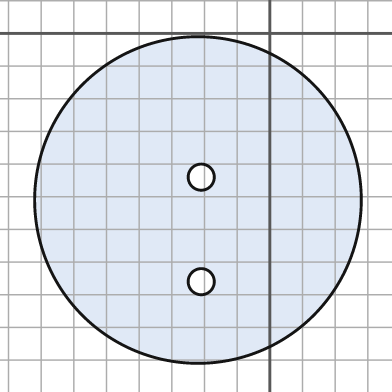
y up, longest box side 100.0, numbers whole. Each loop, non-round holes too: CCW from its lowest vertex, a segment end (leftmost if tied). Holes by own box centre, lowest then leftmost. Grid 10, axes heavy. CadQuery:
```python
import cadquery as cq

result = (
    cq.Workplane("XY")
    .moveTo(-22.0, -51.0)
    .circle(50.0)
    .moveTo(-21.0, -76.0)
    .circle(4.0)
    .moveTo(-21.0, -44.0)
    .circle(4.0)
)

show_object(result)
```